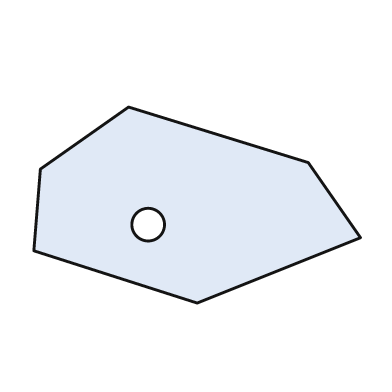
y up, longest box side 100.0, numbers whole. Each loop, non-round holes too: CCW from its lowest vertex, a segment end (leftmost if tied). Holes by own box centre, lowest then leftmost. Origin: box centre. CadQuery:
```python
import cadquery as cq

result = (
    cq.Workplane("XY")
    .moveTo(0.0, -30.0)
    .lineTo(50.0, -10.0)
    .lineTo(34.0, 13.0)
    .lineTo(-21.0, 30.0)
    .lineTo(-48.0, 11.0)
    .lineTo(-50.0, -14.0)
    .close()
    .moveTo(-15.0, -6.0)
    .circle(5.0)
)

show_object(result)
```